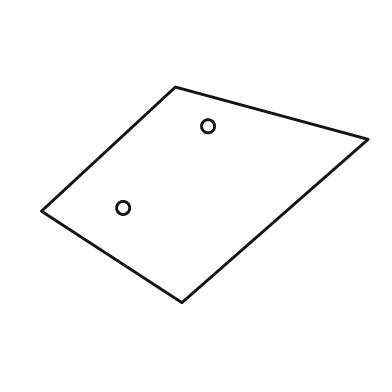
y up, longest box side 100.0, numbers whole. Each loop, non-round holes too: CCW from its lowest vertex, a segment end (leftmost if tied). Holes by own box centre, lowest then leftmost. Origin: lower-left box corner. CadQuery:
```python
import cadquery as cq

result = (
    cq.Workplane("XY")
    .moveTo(43.0, 0.0)
    .lineTo(100.0, 50.0)
    .lineTo(41.0, 66.0)
    .lineTo(0.0, 28.0)
    .close()
    .moveTo(25.0, 29.0)
    .circle(2.0)
    .moveTo(51.0, 54.0)
    .circle(2.0)
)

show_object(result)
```